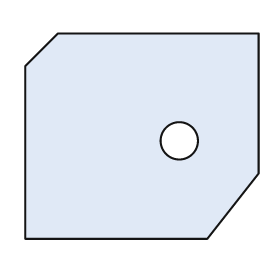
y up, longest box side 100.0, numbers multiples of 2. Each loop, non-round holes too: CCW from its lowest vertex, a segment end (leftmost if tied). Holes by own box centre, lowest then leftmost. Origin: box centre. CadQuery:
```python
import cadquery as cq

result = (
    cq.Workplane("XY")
    .moveTo(-50.0, -44.0)
    .lineTo(28.0, -44.0)
    .lineTo(50.0, -16.0)
    .lineTo(50.0, 44.0)
    .lineTo(-36.0, 44.0)
    .lineTo(-50.0, 30.0)
    .close()
    .moveTo(16.0, -2.0)
    .circle(8.0)
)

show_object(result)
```